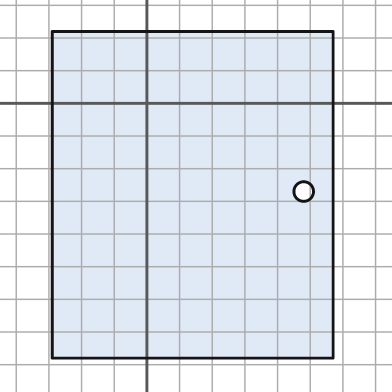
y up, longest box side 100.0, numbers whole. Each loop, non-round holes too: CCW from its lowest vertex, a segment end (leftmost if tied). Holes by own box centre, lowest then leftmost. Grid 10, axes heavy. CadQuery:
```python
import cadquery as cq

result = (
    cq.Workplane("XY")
    .moveTo(-29.0, -78.0)
    .lineTo(57.0, -78.0)
    .lineTo(57.0, 22.0)
    .lineTo(-29.0, 22.0)
    .close()
    .moveTo(48.0, -27.0)
    .circle(3.0)
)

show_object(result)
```